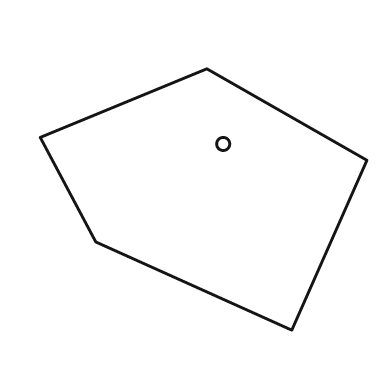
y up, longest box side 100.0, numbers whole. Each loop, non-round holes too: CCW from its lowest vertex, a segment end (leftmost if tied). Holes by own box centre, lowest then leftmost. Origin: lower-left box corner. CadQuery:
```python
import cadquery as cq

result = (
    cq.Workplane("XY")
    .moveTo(77.0, 0.0)
    .lineTo(100.0, 52.0)
    .lineTo(51.0, 80.0)
    .lineTo(0.0, 59.0)
    .lineTo(17.0, 27.0)
    .close()
    .moveTo(56.0, 57.0)
    .circle(2.0)
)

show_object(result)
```